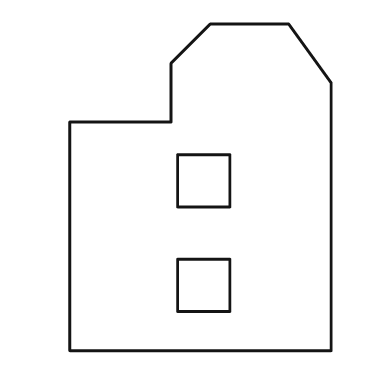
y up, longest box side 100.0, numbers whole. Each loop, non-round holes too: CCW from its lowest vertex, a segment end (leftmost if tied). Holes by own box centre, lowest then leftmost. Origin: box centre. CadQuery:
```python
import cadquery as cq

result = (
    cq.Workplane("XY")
    .moveTo(-40.0, -50.0)
    .lineTo(40.0, -50.0)
    .lineTo(40.0, 32.0)
    .lineTo(27.0, 50.0)
    .lineTo(3.0, 50.0)
    .lineTo(-9.0, 38.0)
    .lineTo(-9.0, 20.0)
    .lineTo(-40.0, 20.0)
    .close()
    .moveTo(-7.0, -38.0)
    .lineTo(9.0, -38.0)
    .lineTo(9.0, -22.0)
    .lineTo(-7.0, -22.0)
    .close()
    .moveTo(-7.0, -6.0)
    .lineTo(9.0, -6.0)
    .lineTo(9.0, 10.0)
    .lineTo(-7.0, 10.0)
    .close()
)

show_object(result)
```